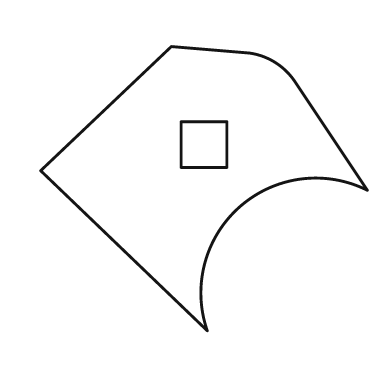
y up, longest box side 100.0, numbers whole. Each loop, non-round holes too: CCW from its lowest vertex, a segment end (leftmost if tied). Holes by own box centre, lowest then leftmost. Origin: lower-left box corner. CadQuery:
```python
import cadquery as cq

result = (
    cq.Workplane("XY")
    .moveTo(51.0, 0.0)
    .threePointArc((61.0, 38.0), (100.0, 43.0))
    .lineTo(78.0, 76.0)
    .threePointArc((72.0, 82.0), (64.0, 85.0))
    .lineTo(40.0, 87.0)
    .lineTo(0.0, 49.0)
    .close()
    .moveTo(43.0, 50.0)
    .lineTo(57.0, 50.0)
    .lineTo(57.0, 64.0)
    .lineTo(43.0, 64.0)
    .close()
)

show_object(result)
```